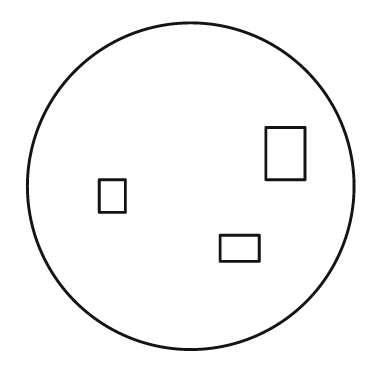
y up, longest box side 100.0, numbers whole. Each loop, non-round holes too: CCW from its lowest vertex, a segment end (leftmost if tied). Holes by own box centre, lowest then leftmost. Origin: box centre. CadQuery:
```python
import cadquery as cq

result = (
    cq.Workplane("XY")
    .moveTo(0.0, 0.0)
    .circle(50.0)
    .moveTo(9.0, -23.0)
    .lineTo(21.0, -23.0)
    .lineTo(21.0, -15.0)
    .lineTo(9.0, -15.0)
    .close()
    .moveTo(-28.0, -8.0)
    .lineTo(-20.0, -8.0)
    .lineTo(-20.0, 2.0)
    .lineTo(-28.0, 2.0)
    .close()
    .moveTo(23.0, 2.0)
    .lineTo(35.0, 2.0)
    .lineTo(35.0, 18.0)
    .lineTo(23.0, 18.0)
    .close()
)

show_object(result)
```